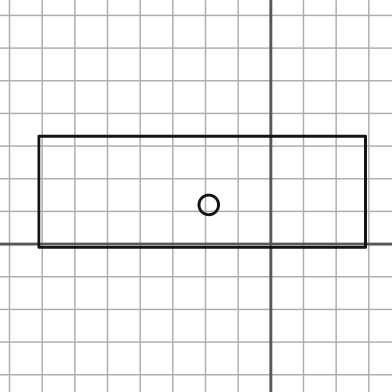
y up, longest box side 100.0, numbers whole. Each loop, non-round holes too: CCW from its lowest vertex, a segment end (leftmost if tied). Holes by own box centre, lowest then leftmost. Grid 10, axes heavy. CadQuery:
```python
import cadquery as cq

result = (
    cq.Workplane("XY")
    .moveTo(-71.0, -1.0)
    .lineTo(29.0, -1.0)
    .lineTo(29.0, 33.0)
    .lineTo(-71.0, 33.0)
    .close()
    .moveTo(-19.0, 12.0)
    .circle(3.0)
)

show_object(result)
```